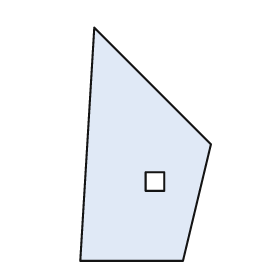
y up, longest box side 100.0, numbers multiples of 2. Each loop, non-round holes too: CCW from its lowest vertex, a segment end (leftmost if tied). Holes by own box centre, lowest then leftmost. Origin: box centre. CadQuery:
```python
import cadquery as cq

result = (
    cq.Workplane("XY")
    .moveTo(-28.0, -50.0)
    .lineTo(16.0, -50.0)
    .lineTo(28.0, 0.0)
    .lineTo(-22.0, 50.0)
    .close()
    .moveTo(0.0, -20.0)
    .lineTo(8.0, -20.0)
    .lineTo(8.0, -12.0)
    .lineTo(0.0, -12.0)
    .close()
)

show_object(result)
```